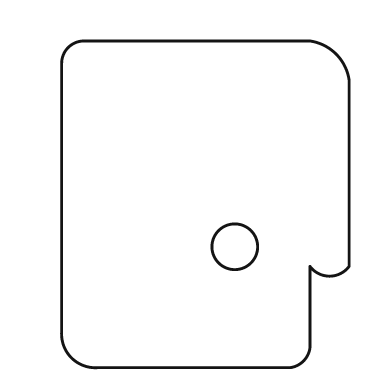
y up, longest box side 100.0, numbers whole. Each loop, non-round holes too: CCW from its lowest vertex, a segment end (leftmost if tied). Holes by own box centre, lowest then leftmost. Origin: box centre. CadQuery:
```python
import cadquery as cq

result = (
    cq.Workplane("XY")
    .moveTo(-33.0, -50.0)
    .lineTo(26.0, -50.0)
    .threePointArc((30.0, -48.0), (32.0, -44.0))
    .lineTo(32.0, -19.0)
    .threePointArc((38.0, -22.0), (44.0, -19.0))
    .lineTo(44.0, 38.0)
    .threePointArc((40.0, 46.0), (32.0, 50.0))
    .lineTo(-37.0, 50.0)
    .threePointArc((-42.0, 48.0), (-44.0, 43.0))
    .lineTo(-44.0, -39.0)
    .threePointArc((-41.0, -47.0), (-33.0, -50.0))
    .close()
    .moveTo(9.0, -13.0)
    .circle(7.0)
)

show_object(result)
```